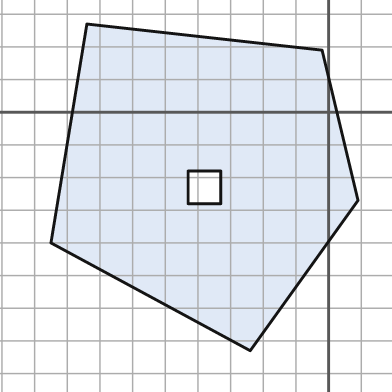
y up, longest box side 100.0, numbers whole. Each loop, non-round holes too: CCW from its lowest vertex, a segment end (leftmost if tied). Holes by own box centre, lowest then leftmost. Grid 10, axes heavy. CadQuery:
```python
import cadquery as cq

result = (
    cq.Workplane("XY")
    .moveTo(-24.0, -73.0)
    .lineTo(9.0, -27.0)
    .lineTo(-2.0, 19.0)
    .lineTo(-74.0, 27.0)
    .lineTo(-85.0, -40.0)
    .close()
    .moveTo(-43.0, -28.0)
    .lineTo(-33.0, -28.0)
    .lineTo(-33.0, -18.0)
    .lineTo(-43.0, -18.0)
    .close()
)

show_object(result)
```